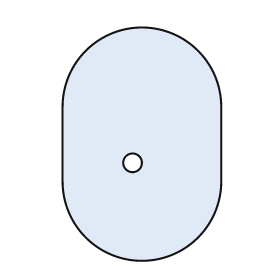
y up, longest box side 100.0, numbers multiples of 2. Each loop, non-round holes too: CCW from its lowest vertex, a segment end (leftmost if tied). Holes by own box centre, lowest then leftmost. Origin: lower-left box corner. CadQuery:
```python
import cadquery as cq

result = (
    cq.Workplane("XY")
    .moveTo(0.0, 34.0)
    .threePointArc((34.0, 0.0), (68.0, 34.0))
    .lineTo(68.0, 66.0)
    .threePointArc((34.0, 100.0), (0.0, 66.0))
    .close()
    .moveTo(30.0, 42.0)
    .circle(4.0)
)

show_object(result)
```